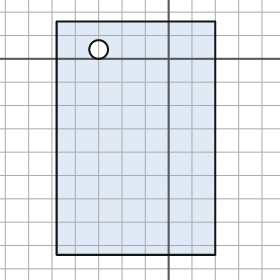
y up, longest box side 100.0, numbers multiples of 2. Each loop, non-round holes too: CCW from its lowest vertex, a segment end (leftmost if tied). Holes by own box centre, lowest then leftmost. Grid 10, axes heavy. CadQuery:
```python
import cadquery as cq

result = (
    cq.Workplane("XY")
    .moveTo(-48.0, -84.0)
    .lineTo(20.0, -84.0)
    .lineTo(20.0, 16.0)
    .lineTo(-48.0, 16.0)
    .close()
    .moveTo(-30.0, 4.0)
    .circle(4.0)
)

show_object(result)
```